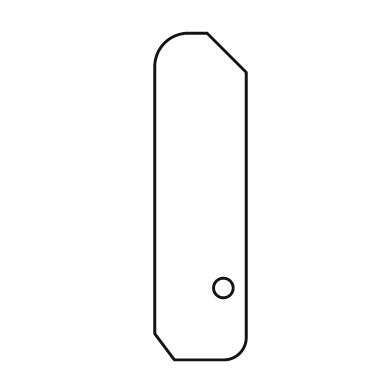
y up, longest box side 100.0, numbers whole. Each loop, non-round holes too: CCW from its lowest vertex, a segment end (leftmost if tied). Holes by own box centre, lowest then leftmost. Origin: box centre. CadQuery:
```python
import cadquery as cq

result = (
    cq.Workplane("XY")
    .moveTo(-8.0, -50.0)
    .lineTo(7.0, -50.0)
    .threePointArc((12.0, -48.0), (14.0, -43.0))
    .lineTo(14.0, 38.0)
    .lineTo(2.0, 50.0)
    .lineTo(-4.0, 50.0)
    .threePointArc((-11.0, 47.0), (-14.0, 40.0))
    .lineTo(-14.0, -42.0)
    .close()
    .moveTo(7.0, -28.0)
    .circle(3.0)
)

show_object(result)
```